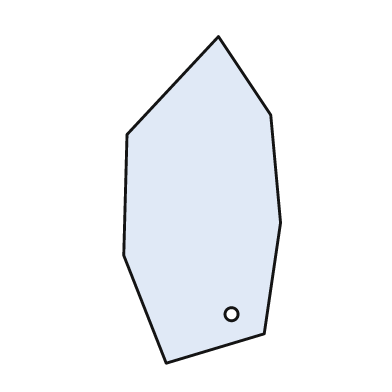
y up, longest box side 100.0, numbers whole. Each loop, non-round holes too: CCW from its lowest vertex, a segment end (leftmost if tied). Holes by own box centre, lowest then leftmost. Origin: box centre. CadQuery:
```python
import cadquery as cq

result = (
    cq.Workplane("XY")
    .moveTo(-11.0, -50.0)
    .lineTo(19.0, -41.0)
    .lineTo(24.0, -7.0)
    .lineTo(21.0, 26.0)
    .lineTo(5.0, 50.0)
    .lineTo(-23.0, 20.0)
    .lineTo(-24.0, -17.0)
    .close()
    .moveTo(9.0, -35.0)
    .circle(2.0)
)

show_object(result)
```